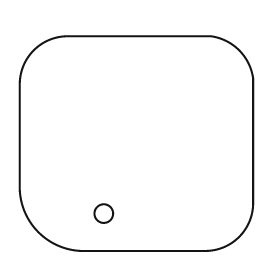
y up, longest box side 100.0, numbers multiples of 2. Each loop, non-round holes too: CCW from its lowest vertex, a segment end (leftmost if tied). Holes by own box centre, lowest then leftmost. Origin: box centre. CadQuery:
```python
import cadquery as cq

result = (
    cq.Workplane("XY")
    .moveTo(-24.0, -46.0)
    .lineTo(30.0, -46.0)
    .threePointArc((44.0, -40.0), (50.0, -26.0))
    .lineTo(50.0, 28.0)
    .threePointArc((44.0, 40.0), (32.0, 46.0))
    .lineTo(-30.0, 46.0)
    .threePointArc((-44.0, 40.0), (-50.0, 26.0))
    .lineTo(-50.0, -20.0)
    .threePointArc((-42.0, -38.0), (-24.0, -46.0))
    .close()
    .moveTo(-14.0, -30.0)
    .circle(4.0)
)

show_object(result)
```